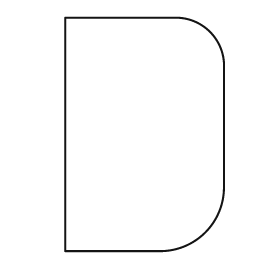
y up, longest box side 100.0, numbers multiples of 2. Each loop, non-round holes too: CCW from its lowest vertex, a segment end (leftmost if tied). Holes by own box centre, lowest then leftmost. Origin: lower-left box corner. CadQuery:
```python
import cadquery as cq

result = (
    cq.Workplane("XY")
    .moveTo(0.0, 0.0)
    .lineTo(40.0, 0.0)
    .threePointArc((60.0, 8.0), (68.0, 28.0))
    .lineTo(68.0, 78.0)
    .threePointArc((62.0, 94.0), (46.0, 100.0))
    .lineTo(0.0, 100.0)
    .close()
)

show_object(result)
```